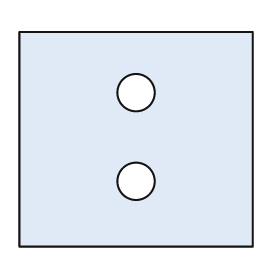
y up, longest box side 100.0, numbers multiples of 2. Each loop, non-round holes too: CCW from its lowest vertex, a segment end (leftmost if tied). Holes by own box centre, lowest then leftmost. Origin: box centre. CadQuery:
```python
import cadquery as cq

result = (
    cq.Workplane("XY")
    .moveTo(-50.0, -46.0)
    .lineTo(50.0, -46.0)
    .lineTo(50.0, 46.0)
    .lineTo(-50.0, 46.0)
    .close()
    .moveTo(0.0, -18.0)
    .circle(8.0)
    .moveTo(0.0, 20.0)
    .circle(8.0)
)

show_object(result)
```